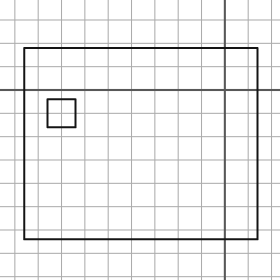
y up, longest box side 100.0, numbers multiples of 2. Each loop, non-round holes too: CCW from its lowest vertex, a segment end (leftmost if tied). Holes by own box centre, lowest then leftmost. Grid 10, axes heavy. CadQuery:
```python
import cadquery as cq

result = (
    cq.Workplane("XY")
    .moveTo(-86.0, -64.0)
    .lineTo(14.0, -64.0)
    .lineTo(14.0, 18.0)
    .lineTo(-86.0, 18.0)
    .close()
    .moveTo(-76.0, -16.0)
    .lineTo(-64.0, -16.0)
    .lineTo(-64.0, -4.0)
    .lineTo(-76.0, -4.0)
    .close()
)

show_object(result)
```